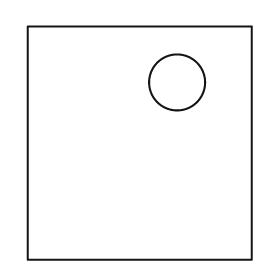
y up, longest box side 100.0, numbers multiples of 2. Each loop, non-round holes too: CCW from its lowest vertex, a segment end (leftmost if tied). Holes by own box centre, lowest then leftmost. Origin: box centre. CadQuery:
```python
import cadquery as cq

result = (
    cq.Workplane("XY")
    .moveTo(-48.0, -50.0)
    .lineTo(48.0, -50.0)
    .lineTo(48.0, 50.0)
    .lineTo(-48.0, 50.0)
    .close()
    .moveTo(16.0, 26.0)
    .circle(12.0)
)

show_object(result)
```